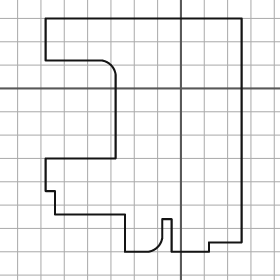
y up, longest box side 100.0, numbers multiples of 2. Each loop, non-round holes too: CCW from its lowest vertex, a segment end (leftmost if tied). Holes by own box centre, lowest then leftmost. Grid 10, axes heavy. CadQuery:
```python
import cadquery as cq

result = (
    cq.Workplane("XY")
    .moveTo(-24.0, -70.0)
    .lineTo(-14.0, -70.0)
    .threePointArc((-10.0, -68.0), (-8.0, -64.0))
    .lineTo(-8.0, -56.0)
    .lineTo(-4.0, -56.0)
    .lineTo(-4.0, -70.0)
    .lineTo(12.0, -70.0)
    .lineTo(12.0, -66.0)
    .lineTo(26.0, -66.0)
    .lineTo(26.0, 30.0)
    .lineTo(-58.0, 30.0)
    .lineTo(-58.0, 12.0)
    .lineTo(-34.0, 12.0)
    .threePointArc((-30.0, 10.0), (-28.0, 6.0))
    .lineTo(-28.0, -30.0)
    .lineTo(-58.0, -30.0)
    .lineTo(-58.0, -44.0)
    .lineTo(-54.0, -44.0)
    .lineTo(-54.0, -54.0)
    .lineTo(-24.0, -54.0)
    .close()
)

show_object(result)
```